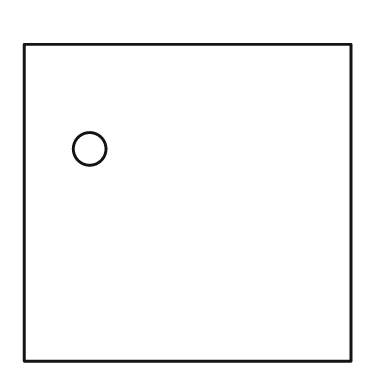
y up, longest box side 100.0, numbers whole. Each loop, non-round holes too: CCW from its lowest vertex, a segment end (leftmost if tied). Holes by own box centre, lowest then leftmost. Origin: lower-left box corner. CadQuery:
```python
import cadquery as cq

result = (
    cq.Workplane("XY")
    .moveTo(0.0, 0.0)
    .lineTo(100.0, 0.0)
    .lineTo(100.0, 97.0)
    .lineTo(0.0, 97.0)
    .close()
    .moveTo(20.0, 65.0)
    .circle(5.0)
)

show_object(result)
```